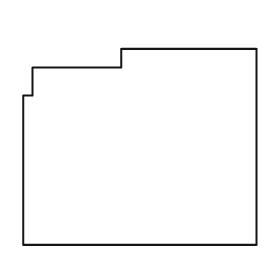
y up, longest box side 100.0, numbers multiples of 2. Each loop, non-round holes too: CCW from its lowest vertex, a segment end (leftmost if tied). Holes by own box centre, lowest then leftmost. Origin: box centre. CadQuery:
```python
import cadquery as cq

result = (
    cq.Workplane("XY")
    .moveTo(-50.0, -42.0)
    .lineTo(50.0, -42.0)
    .lineTo(50.0, 42.0)
    .lineTo(-8.0, 42.0)
    .lineTo(-8.0, 34.0)
    .lineTo(-46.0, 34.0)
    .lineTo(-46.0, 22.0)
    .lineTo(-50.0, 22.0)
    .close()
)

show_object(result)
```